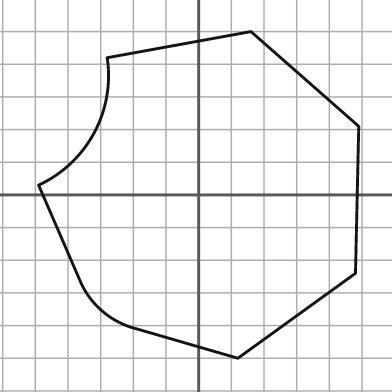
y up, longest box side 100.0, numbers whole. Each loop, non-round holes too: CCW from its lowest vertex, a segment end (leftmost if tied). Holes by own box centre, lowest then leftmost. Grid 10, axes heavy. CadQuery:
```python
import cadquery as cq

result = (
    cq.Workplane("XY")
    .moveTo(12.0, -50.0)
    .lineTo(48.0, -24.0)
    .lineTo(49.0, 21.0)
    .lineTo(16.0, 50.0)
    .lineTo(-28.0, 42.0)
    .threePointArc((-32.0, 19.0), (-49.0, 3.0))
    .lineTo(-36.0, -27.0)
    .threePointArc((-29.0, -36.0), (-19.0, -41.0))
    .close()
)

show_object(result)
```